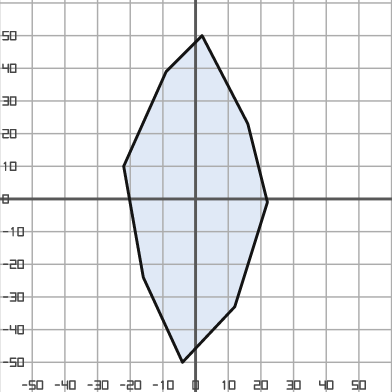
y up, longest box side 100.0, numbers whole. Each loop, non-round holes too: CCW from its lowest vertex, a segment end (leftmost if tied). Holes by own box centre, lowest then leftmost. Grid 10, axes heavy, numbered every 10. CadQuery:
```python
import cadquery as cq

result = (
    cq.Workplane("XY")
    .moveTo(-4.0, -50.0)
    .lineTo(12.0, -33.0)
    .lineTo(22.0, -1.0)
    .lineTo(16.0, 23.0)
    .lineTo(2.0, 50.0)
    .lineTo(-9.0, 39.0)
    .lineTo(-22.0, 10.0)
    .lineTo(-16.0, -24.0)
    .close()
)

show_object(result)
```